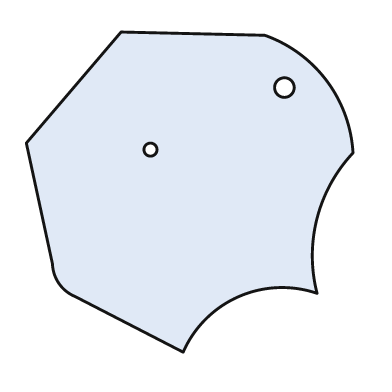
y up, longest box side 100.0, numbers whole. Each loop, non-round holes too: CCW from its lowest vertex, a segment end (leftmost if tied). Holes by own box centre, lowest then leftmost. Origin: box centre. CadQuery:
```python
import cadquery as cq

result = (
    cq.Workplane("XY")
    .moveTo(-2.0, -49.0)
    .threePointArc((15.0, -32.0), (39.0, -31.0))
    .threePointArc((39.0, -8.0), (50.0, 12.0))
    .threePointArc((42.0, 34.0), (23.0, 48.0))
    .lineTo(-21.0, 49.0)
    .lineTo(-50.0, 15.0)
    .lineTo(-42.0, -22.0)
    .threePointArc((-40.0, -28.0), (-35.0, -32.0))
    .close()
    .moveTo(-12.0, 13.0)
    .circle(2.0)
    .moveTo(29.0, 32.0)
    .circle(3.0)
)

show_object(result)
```